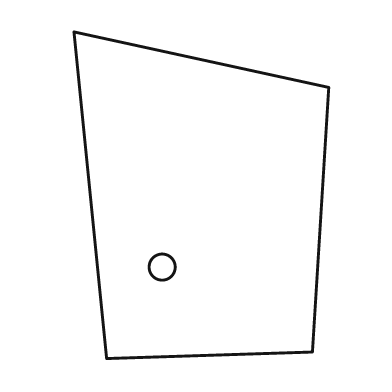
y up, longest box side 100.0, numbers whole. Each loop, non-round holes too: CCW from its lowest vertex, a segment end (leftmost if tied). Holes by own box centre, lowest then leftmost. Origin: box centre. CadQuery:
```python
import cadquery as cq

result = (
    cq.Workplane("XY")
    .moveTo(-29.0, -50.0)
    .lineTo(34.0, -48.0)
    .lineTo(39.0, 33.0)
    .lineTo(-39.0, 50.0)
    .close()
    .moveTo(-12.0, -22.0)
    .circle(4.0)
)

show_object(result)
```